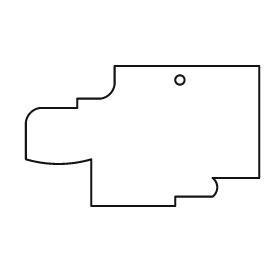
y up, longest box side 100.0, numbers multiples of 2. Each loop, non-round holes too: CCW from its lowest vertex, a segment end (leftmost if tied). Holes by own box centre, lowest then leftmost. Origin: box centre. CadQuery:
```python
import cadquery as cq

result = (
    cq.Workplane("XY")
    .moveTo(-22.0, -30.0)
    .lineTo(14.0, -30.0)
    .lineTo(14.0, -26.0)
    .lineTo(30.0, -26.0)
    .threePointArc((32.0, -22.0), (30.0, -18.0))
    .lineTo(50.0, -18.0)
    .lineTo(50.0, 30.0)
    .lineTo(-12.0, 30.0)
    .lineTo(-12.0, 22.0)
    .threePointArc((-14.0, 18.0), (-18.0, 16.0))
    .lineTo(-28.0, 16.0)
    .lineTo(-28.0, 12.0)
    .lineTo(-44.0, 12.0)
    .threePointArc((-48.0, 10.0), (-50.0, 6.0))
    .lineTo(-50.0, -10.0)
    .threePointArc((-36.0, -12.0), (-22.0, -10.0))
    .close()
    .moveTo(16.0, 24.0)
    .circle(2.0)
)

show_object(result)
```